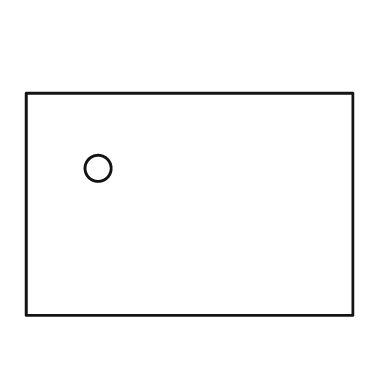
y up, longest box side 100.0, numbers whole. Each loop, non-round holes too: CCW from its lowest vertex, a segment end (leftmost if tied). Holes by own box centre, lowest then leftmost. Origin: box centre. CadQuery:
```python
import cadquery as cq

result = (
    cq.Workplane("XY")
    .moveTo(-50.0, -34.0)
    .lineTo(50.0, -34.0)
    .lineTo(50.0, 34.0)
    .lineTo(-50.0, 34.0)
    .close()
    .moveTo(-28.0, 11.0)
    .circle(4.0)
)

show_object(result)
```